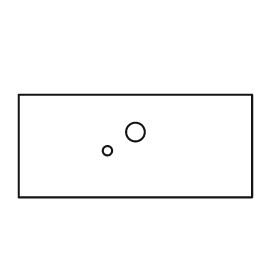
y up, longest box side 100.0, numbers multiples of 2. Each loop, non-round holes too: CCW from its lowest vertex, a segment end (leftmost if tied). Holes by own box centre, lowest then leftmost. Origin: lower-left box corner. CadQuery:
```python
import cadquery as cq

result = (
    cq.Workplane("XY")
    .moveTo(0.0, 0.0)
    .lineTo(100.0, 0.0)
    .lineTo(100.0, 44.0)
    .lineTo(0.0, 44.0)
    .close()
    .moveTo(38.0, 20.0)
    .circle(2.0)
    .moveTo(50.0, 28.0)
    .circle(4.0)
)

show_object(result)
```